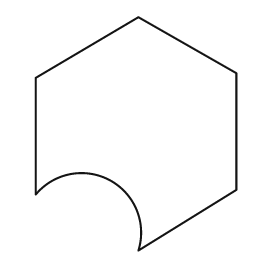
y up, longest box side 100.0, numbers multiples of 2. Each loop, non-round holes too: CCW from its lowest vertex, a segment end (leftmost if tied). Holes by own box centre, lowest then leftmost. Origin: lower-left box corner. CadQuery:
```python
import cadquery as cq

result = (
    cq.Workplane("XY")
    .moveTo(44.0, 0.0)
    .lineTo(86.0, 26.0)
    .lineTo(86.0, 76.0)
    .lineTo(44.0, 100.0)
    .lineTo(0.0, 74.0)
    .lineTo(0.0, 24.0)
    .threePointArc((32.0, 30.0), (44.0, 0.0))
    .close()
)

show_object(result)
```